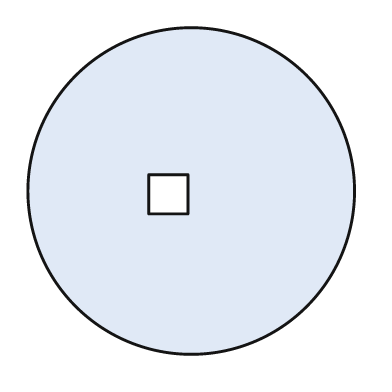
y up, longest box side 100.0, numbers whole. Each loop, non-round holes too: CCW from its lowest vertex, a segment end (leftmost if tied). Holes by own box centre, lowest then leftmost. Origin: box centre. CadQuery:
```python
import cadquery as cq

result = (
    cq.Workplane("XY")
    .moveTo(0.0, 0.0)
    .circle(50.0)
    .moveTo(-13.0, -7.0)
    .lineTo(-1.0, -7.0)
    .lineTo(-1.0, 5.0)
    .lineTo(-13.0, 5.0)
    .close()
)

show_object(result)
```